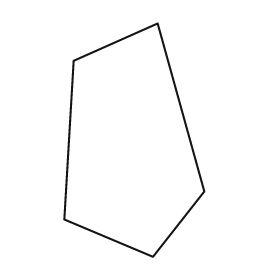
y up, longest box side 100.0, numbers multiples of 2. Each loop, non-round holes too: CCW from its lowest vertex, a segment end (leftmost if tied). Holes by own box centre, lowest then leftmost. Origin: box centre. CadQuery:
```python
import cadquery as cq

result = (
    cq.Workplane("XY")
    .moveTo(8.0, -50.0)
    .lineTo(30.0, -22.0)
    .lineTo(10.0, 50.0)
    .lineTo(-26.0, 34.0)
    .lineTo(-30.0, -34.0)
    .close()
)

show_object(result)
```